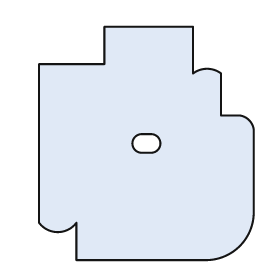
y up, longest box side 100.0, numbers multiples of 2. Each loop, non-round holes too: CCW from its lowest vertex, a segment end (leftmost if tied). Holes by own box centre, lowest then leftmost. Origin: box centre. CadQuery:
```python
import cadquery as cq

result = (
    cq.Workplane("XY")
    .moveTo(-30.0, -50.0)
    .lineTo(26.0, -50.0)
    .threePointArc((40.0, -44.0), (46.0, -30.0))
    .lineTo(46.0, 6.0)
    .threePointArc((44.0, 10.0), (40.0, 12.0))
    .lineTo(32.0, 12.0)
    .lineTo(32.0, 30.0)
    .threePointArc((26.0, 32.0), (20.0, 30.0))
    .lineTo(20.0, 50.0)
    .lineTo(-18.0, 50.0)
    .lineTo(-18.0, 34.0)
    .lineTo(-46.0, 34.0)
    .lineTo(-46.0, -34.0)
    .threePointArc((-38.0, -38.0), (-30.0, -34.0))
    .close()
    .moveTo(-2.0, -4.0)
    .lineTo(2.0, -4.0)
    .threePointArc((6.0, 0.0), (2.0, 4.0))
    .lineTo(-2.0, 4.0)
    .threePointArc((-6.0, 0.0), (-2.0, -4.0))
    .close()
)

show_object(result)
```